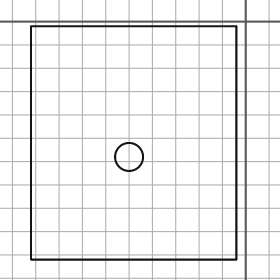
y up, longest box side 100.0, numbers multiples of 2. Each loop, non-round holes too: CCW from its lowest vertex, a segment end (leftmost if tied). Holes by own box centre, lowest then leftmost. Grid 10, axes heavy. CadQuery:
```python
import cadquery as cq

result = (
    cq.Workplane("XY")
    .moveTo(-92.0, -102.0)
    .lineTo(-4.0, -102.0)
    .lineTo(-4.0, -2.0)
    .lineTo(-92.0, -2.0)
    .close()
    .moveTo(-50.0, -58.0)
    .circle(6.0)
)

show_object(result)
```